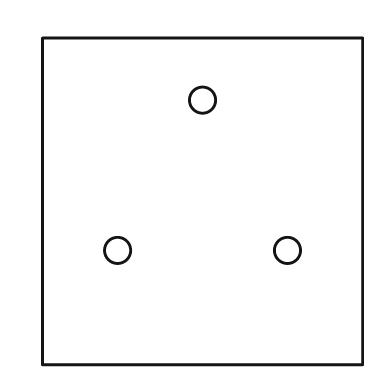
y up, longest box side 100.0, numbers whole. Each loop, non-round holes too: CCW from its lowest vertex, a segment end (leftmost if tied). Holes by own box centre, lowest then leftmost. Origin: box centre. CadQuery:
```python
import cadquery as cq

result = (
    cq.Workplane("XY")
    .moveTo(-49.0, -50.0)
    .lineTo(49.0, -50.0)
    .lineTo(49.0, 50.0)
    .lineTo(-49.0, 50.0)
    .close()
    .moveTo(-26.0, -15.0)
    .circle(4.0)
    .moveTo(26.0, -15.0)
    .circle(4.0)
    .moveTo(0.0, 31.0)
    .circle(4.0)
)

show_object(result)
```